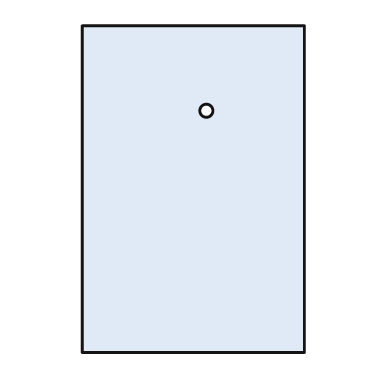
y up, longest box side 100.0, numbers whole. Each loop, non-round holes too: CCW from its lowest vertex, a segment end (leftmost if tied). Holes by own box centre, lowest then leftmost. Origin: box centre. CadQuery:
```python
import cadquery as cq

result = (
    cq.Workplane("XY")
    .moveTo(-34.0, -50.0)
    .lineTo(34.0, -50.0)
    .lineTo(34.0, 50.0)
    .lineTo(-34.0, 50.0)
    .close()
    .moveTo(4.0, 24.0)
    .circle(2.0)
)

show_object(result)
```